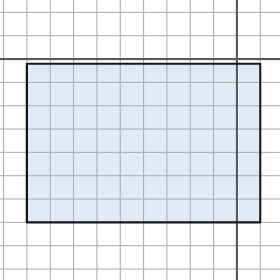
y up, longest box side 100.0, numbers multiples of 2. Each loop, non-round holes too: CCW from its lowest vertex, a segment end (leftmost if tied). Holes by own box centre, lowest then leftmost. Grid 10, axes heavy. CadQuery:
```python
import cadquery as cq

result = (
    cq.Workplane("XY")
    .moveTo(-90.0, -70.0)
    .lineTo(10.0, -70.0)
    .lineTo(10.0, -2.0)
    .lineTo(-90.0, -2.0)
    .close()
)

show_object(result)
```